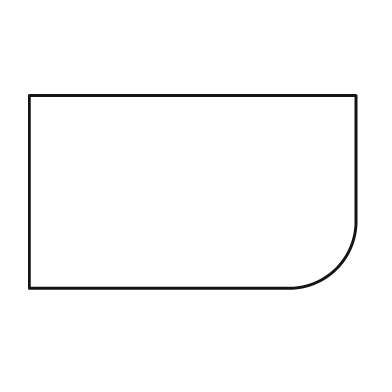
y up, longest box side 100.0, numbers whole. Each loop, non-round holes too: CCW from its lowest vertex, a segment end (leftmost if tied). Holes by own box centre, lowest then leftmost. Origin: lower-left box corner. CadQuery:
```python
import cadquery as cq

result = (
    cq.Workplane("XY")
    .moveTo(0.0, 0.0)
    .lineTo(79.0, 0.0)
    .threePointArc((94.0, 6.0), (100.0, 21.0))
    .lineTo(100.0, 59.0)
    .lineTo(0.0, 59.0)
    .close()
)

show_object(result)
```